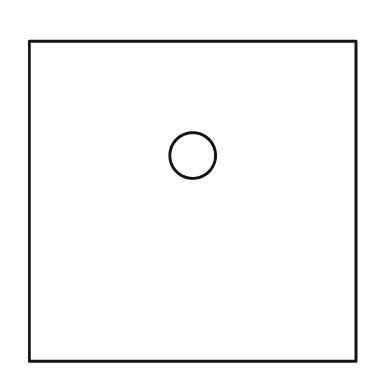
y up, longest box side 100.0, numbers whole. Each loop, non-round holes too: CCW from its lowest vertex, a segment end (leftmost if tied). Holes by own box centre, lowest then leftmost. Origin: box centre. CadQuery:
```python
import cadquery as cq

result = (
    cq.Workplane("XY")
    .moveTo(-50.0, -49.0)
    .lineTo(50.0, -49.0)
    .lineTo(50.0, 49.0)
    .lineTo(-50.0, 49.0)
    .close()
    .moveTo(0.0, 14.0)
    .circle(7.0)
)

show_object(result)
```